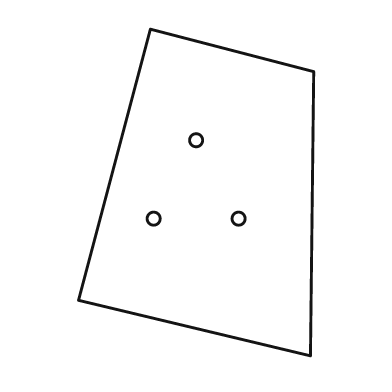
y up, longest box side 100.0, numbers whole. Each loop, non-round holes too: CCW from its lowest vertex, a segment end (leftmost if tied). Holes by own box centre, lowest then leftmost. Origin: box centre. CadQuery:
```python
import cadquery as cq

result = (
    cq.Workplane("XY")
    .moveTo(35.0, -50.0)
    .lineTo(36.0, 37.0)
    .lineTo(-14.0, 50.0)
    .lineTo(-36.0, -33.0)
    .close()
    .moveTo(-13.0, -8.0)
    .circle(2.0)
    .moveTo(13.0, -8.0)
    .circle(2.0)
    .moveTo(0.0, 16.0)
    .circle(2.0)
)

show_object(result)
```